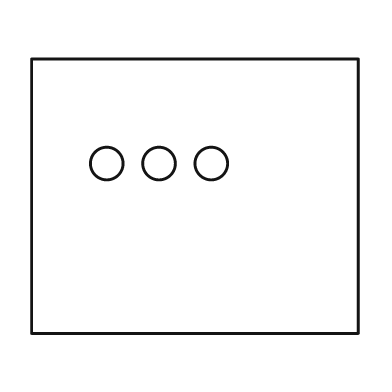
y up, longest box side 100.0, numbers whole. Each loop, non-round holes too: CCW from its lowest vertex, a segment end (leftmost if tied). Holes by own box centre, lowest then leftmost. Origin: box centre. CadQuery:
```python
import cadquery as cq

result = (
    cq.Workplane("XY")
    .moveTo(-50.0, -42.0)
    .lineTo(50.0, -42.0)
    .lineTo(50.0, 42.0)
    .lineTo(-50.0, 42.0)
    .close()
    .moveTo(-27.0, 10.0)
    .circle(5.0)
    .moveTo(-11.0, 10.0)
    .circle(5.0)
    .moveTo(5.0, 10.0)
    .circle(5.0)
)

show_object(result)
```